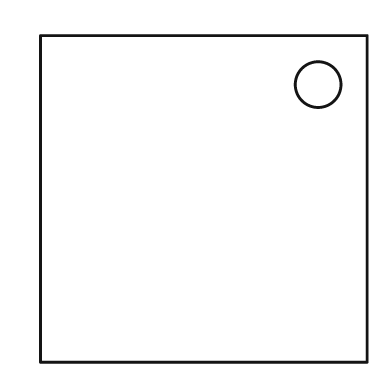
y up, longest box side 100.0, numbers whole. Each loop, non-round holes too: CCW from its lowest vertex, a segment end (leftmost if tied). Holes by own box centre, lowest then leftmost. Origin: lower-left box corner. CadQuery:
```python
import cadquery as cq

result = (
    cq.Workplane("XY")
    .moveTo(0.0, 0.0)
    .lineTo(100.0, 0.0)
    .lineTo(100.0, 100.0)
    .lineTo(0.0, 100.0)
    .close()
    .moveTo(85.0, 85.0)
    .circle(7.0)
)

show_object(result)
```